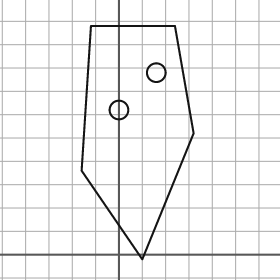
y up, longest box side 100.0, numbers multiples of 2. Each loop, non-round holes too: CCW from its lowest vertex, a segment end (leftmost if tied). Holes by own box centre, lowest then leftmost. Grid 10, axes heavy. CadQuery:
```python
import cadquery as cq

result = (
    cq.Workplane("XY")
    .moveTo(10.0, -2.0)
    .lineTo(32.0, 52.0)
    .lineTo(24.0, 98.0)
    .lineTo(-12.0, 98.0)
    .lineTo(-16.0, 36.0)
    .close()
    .moveTo(0.0, 62.0)
    .circle(4.0)
    .moveTo(16.0, 78.0)
    .circle(4.0)
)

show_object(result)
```